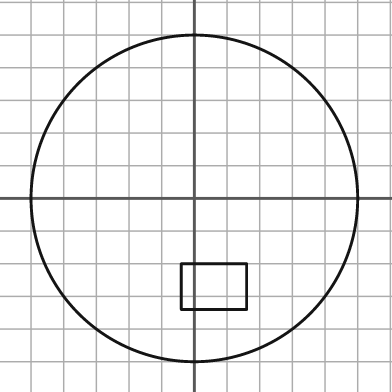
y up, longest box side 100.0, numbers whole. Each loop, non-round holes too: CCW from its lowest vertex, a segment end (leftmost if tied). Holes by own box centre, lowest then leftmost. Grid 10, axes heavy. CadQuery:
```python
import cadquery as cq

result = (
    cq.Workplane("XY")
    .moveTo(0.0, 0.0)
    .circle(50.0)
    .moveTo(-4.0, -34.0)
    .lineTo(16.0, -34.0)
    .lineTo(16.0, -20.0)
    .lineTo(-4.0, -20.0)
    .close()
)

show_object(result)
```